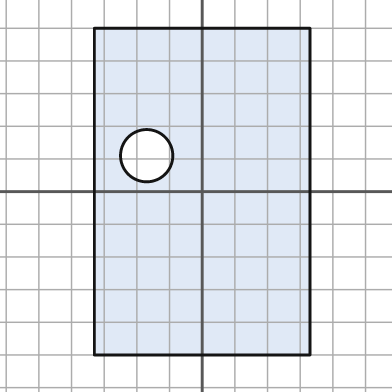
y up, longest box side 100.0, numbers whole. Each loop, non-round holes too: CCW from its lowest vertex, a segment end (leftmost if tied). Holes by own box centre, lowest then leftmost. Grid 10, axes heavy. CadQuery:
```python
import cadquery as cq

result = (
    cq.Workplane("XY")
    .moveTo(-33.0, -50.0)
    .lineTo(33.0, -50.0)
    .lineTo(33.0, 50.0)
    .lineTo(-33.0, 50.0)
    .close()
    .moveTo(-17.0, 11.0)
    .circle(8.0)
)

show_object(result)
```